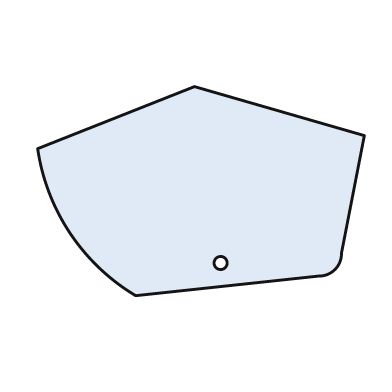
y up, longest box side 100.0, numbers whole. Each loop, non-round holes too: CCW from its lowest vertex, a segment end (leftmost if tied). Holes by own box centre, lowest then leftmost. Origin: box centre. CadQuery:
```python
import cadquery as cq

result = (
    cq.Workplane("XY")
    .moveTo(-20.0, -32.0)
    .lineTo(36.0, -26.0)
    .threePointArc((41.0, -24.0), (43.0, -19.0))
    .lineTo(50.0, 17.0)
    .lineTo(-2.0, 32.0)
    .lineTo(-50.0, 13.0)
    .threePointArc((-40.0, -13.0), (-20.0, -32.0))
    .close()
    .moveTo(6.0, -22.0)
    .circle(2.0)
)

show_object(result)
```